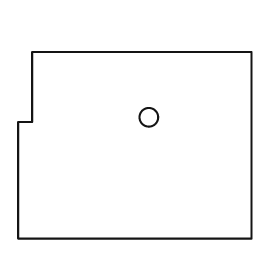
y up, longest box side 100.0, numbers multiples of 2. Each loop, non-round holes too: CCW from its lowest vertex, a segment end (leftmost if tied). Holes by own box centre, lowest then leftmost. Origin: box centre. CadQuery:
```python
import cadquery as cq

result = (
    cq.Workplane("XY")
    .moveTo(-50.0, -40.0)
    .lineTo(50.0, -40.0)
    .lineTo(50.0, 40.0)
    .lineTo(-44.0, 40.0)
    .lineTo(-44.0, 10.0)
    .lineTo(-50.0, 10.0)
    .close()
    .moveTo(6.0, 12.0)
    .circle(4.0)
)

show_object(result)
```